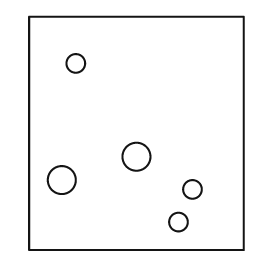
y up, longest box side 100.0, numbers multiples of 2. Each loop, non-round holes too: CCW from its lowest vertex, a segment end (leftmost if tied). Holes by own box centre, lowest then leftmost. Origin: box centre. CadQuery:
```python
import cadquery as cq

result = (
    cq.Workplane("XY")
    .moveTo(-46.0, -50.0)
    .lineTo(46.0, -50.0)
    .lineTo(46.0, 50.0)
    .lineTo(-46.0, 50.0)
    .close()
    .moveTo(18.0, -38.0)
    .circle(4.0)
    .moveTo(24.0, -24.0)
    .circle(4.0)
    .moveTo(-32.0, -20.0)
    .circle(6.0)
    .moveTo(0.0, -10.0)
    .circle(6.0)
    .moveTo(-26.0, 30.0)
    .circle(4.0)
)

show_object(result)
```